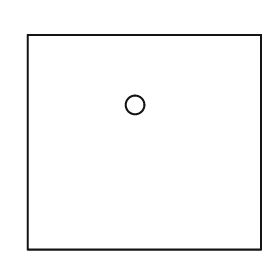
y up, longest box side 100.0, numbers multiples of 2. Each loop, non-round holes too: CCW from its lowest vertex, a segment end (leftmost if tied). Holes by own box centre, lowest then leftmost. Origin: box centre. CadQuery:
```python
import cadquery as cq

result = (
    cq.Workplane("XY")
    .moveTo(-50.0, -46.0)
    .lineTo(50.0, -46.0)
    .lineTo(50.0, 46.0)
    .lineTo(-50.0, 46.0)
    .close()
    .moveTo(-4.0, 16.0)
    .circle(4.0)
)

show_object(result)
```